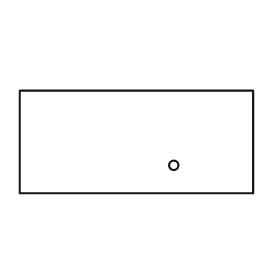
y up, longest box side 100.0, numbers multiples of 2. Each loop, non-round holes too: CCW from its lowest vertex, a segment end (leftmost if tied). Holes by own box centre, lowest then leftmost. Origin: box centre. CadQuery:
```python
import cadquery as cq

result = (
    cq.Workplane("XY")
    .moveTo(-50.0, -22.0)
    .lineTo(50.0, -22.0)
    .lineTo(50.0, 22.0)
    .lineTo(-50.0, 22.0)
    .close()
    .moveTo(16.0, -10.0)
    .circle(2.0)
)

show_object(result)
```